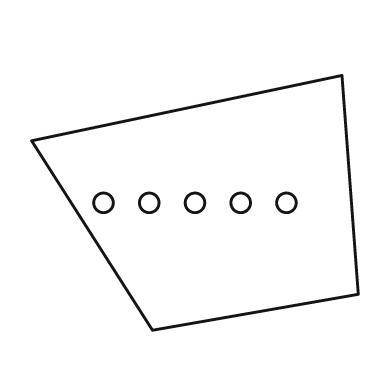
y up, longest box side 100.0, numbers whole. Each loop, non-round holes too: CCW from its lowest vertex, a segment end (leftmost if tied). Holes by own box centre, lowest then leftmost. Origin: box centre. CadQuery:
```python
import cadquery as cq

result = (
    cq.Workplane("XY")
    .moveTo(-13.0, -39.0)
    .lineTo(50.0, -28.0)
    .lineTo(45.0, 39.0)
    .lineTo(-50.0, 19.0)
    .close()
    .moveTo(-28.0, 0.0)
    .circle(3.0)
    .moveTo(-14.0, 0.0)
    .circle(3.0)
    .moveTo(0.0, 0.0)
    .circle(3.0)
    .moveTo(14.0, 0.0)
    .circle(3.0)
    .moveTo(28.0, 0.0)
    .circle(3.0)
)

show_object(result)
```